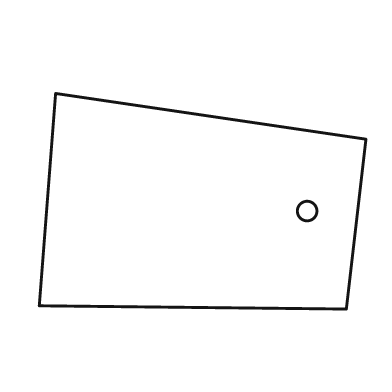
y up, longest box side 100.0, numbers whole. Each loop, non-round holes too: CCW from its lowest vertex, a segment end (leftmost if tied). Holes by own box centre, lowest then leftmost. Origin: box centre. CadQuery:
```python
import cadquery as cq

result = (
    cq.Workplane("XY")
    .moveTo(44.0, -33.0)
    .lineTo(50.0, 19.0)
    .lineTo(-45.0, 33.0)
    .lineTo(-50.0, -32.0)
    .close()
    .moveTo(32.0, -3.0)
    .circle(3.0)
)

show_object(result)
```